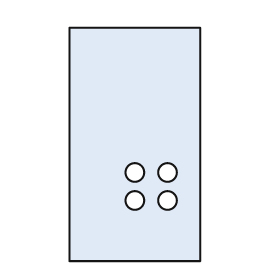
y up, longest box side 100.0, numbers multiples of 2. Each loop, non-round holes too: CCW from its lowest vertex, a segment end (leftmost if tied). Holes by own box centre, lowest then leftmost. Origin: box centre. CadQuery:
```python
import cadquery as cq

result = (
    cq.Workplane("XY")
    .moveTo(-28.0, -50.0)
    .lineTo(28.0, -50.0)
    .lineTo(28.0, 50.0)
    .lineTo(-28.0, 50.0)
    .close()
    .moveTo(0.0, -24.0)
    .circle(4.0)
    .moveTo(14.0, -24.0)
    .circle(4.0)
    .moveTo(0.0, -12.0)
    .circle(4.0)
    .moveTo(14.0, -12.0)
    .circle(4.0)
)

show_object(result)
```